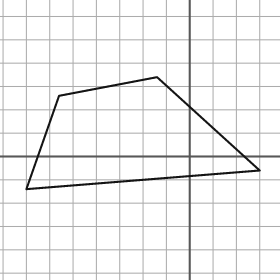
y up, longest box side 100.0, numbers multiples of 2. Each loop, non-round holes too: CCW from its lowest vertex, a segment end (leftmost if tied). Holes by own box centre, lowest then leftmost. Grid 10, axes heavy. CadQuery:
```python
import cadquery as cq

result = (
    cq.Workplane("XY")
    .moveTo(-70.0, -14.0)
    .lineTo(30.0, -6.0)
    .lineTo(-14.0, 34.0)
    .lineTo(-56.0, 26.0)
    .close()
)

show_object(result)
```